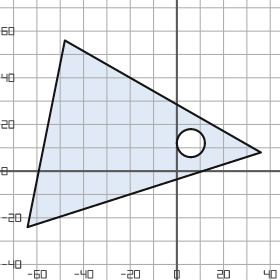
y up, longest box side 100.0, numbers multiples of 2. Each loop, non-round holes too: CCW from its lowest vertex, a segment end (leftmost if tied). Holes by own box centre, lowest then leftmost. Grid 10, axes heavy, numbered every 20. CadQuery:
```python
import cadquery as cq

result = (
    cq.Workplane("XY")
    .moveTo(-64.0, -24.0)
    .lineTo(36.0, 8.0)
    .lineTo(-48.0, 56.0)
    .close()
    .moveTo(6.0, 12.0)
    .circle(6.0)
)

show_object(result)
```